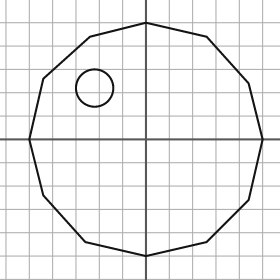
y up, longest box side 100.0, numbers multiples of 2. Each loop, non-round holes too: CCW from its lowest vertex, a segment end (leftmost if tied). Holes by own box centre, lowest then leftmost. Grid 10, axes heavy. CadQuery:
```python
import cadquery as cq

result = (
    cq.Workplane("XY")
    .moveTo(0.0, -50.0)
    .lineTo(26.0, -44.0)
    .lineTo(44.0, -26.0)
    .lineTo(50.0, 0.0)
    .lineTo(44.0, 24.0)
    .lineTo(26.0, 44.0)
    .lineTo(0.0, 50.0)
    .lineTo(-24.0, 44.0)
    .lineTo(-44.0, 26.0)
    .lineTo(-50.0, 0.0)
    .lineTo(-44.0, -24.0)
    .lineTo(-26.0, -44.0)
    .close()
    .moveTo(-22.0, 22.0)
    .circle(8.0)
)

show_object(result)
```